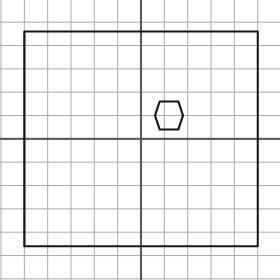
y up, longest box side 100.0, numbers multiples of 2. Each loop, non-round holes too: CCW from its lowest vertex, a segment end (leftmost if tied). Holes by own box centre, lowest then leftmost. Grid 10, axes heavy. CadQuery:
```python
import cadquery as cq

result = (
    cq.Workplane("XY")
    .moveTo(-50.0, -46.0)
    .lineTo(50.0, -46.0)
    .lineTo(50.0, 46.0)
    .lineTo(-50.0, 46.0)
    .close()
    .moveTo(8.0, 4.0)
    .lineTo(16.0, 4.0)
    .lineTo(18.0, 10.0)
    .lineTo(16.0, 16.0)
    .lineTo(8.0, 16.0)
    .lineTo(6.0, 10.0)
    .close()
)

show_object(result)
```